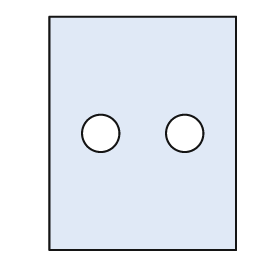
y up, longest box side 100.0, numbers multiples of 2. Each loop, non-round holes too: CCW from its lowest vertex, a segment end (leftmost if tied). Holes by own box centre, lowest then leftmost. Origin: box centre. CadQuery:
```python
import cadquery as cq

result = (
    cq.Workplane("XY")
    .moveTo(-40.0, -50.0)
    .lineTo(40.0, -50.0)
    .lineTo(40.0, 50.0)
    .lineTo(-40.0, 50.0)
    .close()
    .moveTo(-18.0, 0.0)
    .circle(8.0)
    .moveTo(18.0, 0.0)
    .circle(8.0)
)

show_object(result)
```